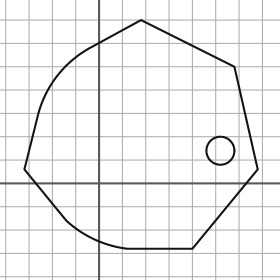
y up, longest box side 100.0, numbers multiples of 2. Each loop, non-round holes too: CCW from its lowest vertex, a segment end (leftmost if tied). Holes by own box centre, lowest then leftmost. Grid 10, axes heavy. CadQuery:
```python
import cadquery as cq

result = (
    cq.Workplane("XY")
    .moveTo(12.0, -28.0)
    .lineTo(40.0, -28.0)
    .lineTo(68.0, 6.0)
    .lineTo(58.0, 50.0)
    .lineTo(18.0, 70.0)
    .lineTo(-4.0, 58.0)
    .threePointArc((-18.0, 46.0), (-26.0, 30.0))
    .lineTo(-32.0, 6.0)
    .lineTo(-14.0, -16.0)
    .threePointArc((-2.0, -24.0), (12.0, -28.0))
    .close()
    .moveTo(52.0, 14.0)
    .circle(6.0)
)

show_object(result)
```